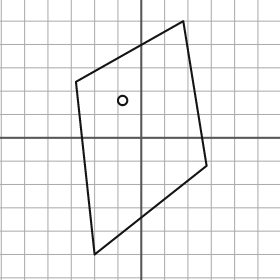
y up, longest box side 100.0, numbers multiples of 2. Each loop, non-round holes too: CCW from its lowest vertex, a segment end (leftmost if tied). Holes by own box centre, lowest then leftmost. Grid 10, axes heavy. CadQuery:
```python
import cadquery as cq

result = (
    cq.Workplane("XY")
    .moveTo(-20.0, -50.0)
    .lineTo(28.0, -12.0)
    .lineTo(18.0, 50.0)
    .lineTo(-28.0, 24.0)
    .close()
    .moveTo(-8.0, 16.0)
    .circle(2.0)
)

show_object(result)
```